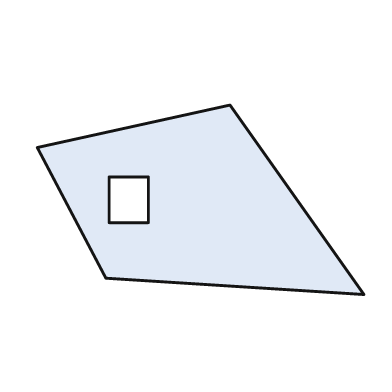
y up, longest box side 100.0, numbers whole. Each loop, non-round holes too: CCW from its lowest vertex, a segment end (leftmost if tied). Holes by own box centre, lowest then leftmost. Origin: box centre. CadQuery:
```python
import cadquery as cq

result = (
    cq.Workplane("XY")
    .moveTo(50.0, -29.0)
    .lineTo(9.0, 29.0)
    .lineTo(-50.0, 16.0)
    .lineTo(-29.0, -24.0)
    .close()
    .moveTo(-28.0, -7.0)
    .lineTo(-16.0, -7.0)
    .lineTo(-16.0, 7.0)
    .lineTo(-28.0, 7.0)
    .close()
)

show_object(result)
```